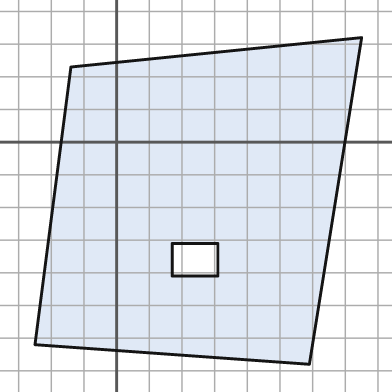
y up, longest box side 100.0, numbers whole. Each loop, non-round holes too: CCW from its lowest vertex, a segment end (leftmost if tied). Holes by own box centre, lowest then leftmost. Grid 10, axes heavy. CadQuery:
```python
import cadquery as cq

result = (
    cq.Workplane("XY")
    .moveTo(59.0, -68.0)
    .lineTo(75.0, 32.0)
    .lineTo(-14.0, 23.0)
    .lineTo(-25.0, -62.0)
    .close()
    .moveTo(17.0, -41.0)
    .lineTo(31.0, -41.0)
    .lineTo(31.0, -31.0)
    .lineTo(17.0, -31.0)
    .close()
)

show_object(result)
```